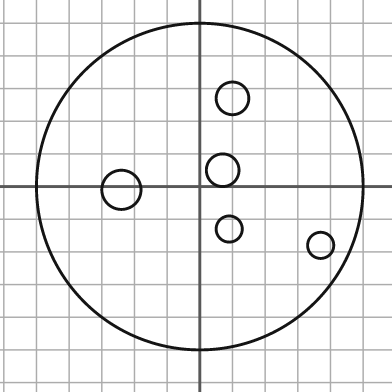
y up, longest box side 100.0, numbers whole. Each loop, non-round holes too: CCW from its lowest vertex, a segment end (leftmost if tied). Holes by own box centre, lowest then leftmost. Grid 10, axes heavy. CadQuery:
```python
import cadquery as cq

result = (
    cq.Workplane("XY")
    .moveTo(0.0, 0.0)
    .circle(50.0)
    .moveTo(37.0, -18.0)
    .circle(4.0)
    .moveTo(9.0, -13.0)
    .circle(4.0)
    .moveTo(-24.0, -1.0)
    .circle(6.0)
    .moveTo(7.0, 5.0)
    .circle(5.0)
    .moveTo(10.0, 27.0)
    .circle(5.0)
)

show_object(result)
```